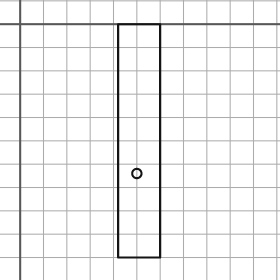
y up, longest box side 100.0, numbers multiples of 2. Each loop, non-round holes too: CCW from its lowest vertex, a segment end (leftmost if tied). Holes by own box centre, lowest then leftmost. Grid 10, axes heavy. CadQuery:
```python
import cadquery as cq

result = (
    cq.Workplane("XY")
    .moveTo(42.0, -100.0)
    .lineTo(60.0, -100.0)
    .lineTo(60.0, 0.0)
    .lineTo(42.0, 0.0)
    .close()
    .moveTo(50.0, -64.0)
    .circle(2.0)
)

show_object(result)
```